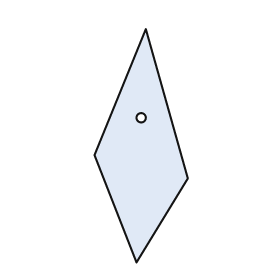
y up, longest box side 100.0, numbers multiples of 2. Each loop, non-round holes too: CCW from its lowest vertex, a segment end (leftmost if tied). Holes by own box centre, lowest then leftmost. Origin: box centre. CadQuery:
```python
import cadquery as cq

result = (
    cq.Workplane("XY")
    .moveTo(-2.0, -50.0)
    .lineTo(20.0, -14.0)
    .lineTo(2.0, 50.0)
    .lineTo(-20.0, -4.0)
    .close()
    .moveTo(0.0, 12.0)
    .circle(2.0)
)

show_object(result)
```